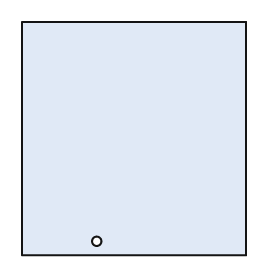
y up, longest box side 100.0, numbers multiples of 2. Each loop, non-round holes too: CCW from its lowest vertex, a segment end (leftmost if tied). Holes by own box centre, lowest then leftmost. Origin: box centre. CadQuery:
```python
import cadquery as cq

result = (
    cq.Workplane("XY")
    .moveTo(-48.0, -50.0)
    .lineTo(48.0, -50.0)
    .lineTo(48.0, 50.0)
    .lineTo(-48.0, 50.0)
    .close()
    .moveTo(-16.0, -44.0)
    .circle(2.0)
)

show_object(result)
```